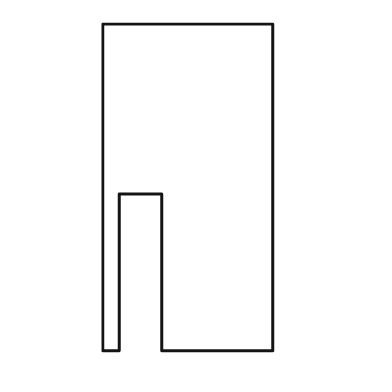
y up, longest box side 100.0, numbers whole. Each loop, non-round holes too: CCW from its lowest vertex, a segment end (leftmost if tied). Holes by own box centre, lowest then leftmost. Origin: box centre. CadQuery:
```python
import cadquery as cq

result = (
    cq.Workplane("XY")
    .moveTo(-26.0, -50.0)
    .lineTo(-21.0, -50.0)
    .lineTo(-21.0, -2.0)
    .lineTo(-8.0, -2.0)
    .lineTo(-8.0, -50.0)
    .lineTo(26.0, -50.0)
    .lineTo(26.0, 50.0)
    .lineTo(-26.0, 50.0)
    .close()
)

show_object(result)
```